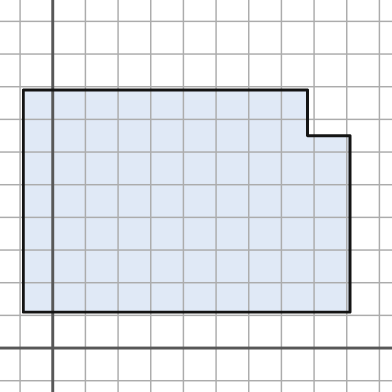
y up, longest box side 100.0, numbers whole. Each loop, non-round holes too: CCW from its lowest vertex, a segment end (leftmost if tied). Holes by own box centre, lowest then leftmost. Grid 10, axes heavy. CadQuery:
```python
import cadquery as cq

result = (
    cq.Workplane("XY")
    .moveTo(-9.0, 11.0)
    .lineTo(91.0, 11.0)
    .lineTo(91.0, 65.0)
    .lineTo(78.0, 65.0)
    .lineTo(78.0, 79.0)
    .lineTo(-9.0, 79.0)
    .close()
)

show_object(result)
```